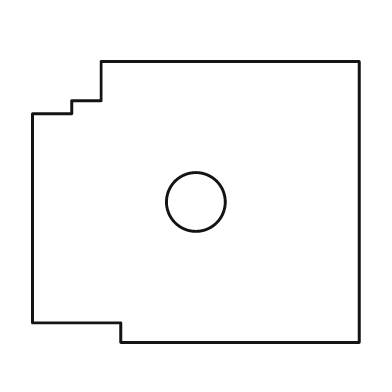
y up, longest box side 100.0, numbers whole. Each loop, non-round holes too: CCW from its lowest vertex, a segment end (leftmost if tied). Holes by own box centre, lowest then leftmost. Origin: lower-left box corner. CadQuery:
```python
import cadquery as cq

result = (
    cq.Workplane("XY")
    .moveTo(27.0, 0.0)
    .lineTo(100.0, 0.0)
    .lineTo(100.0, 86.0)
    .lineTo(21.0, 86.0)
    .lineTo(21.0, 74.0)
    .lineTo(12.0, 74.0)
    .lineTo(12.0, 70.0)
    .lineTo(0.0, 70.0)
    .lineTo(0.0, 6.0)
    .lineTo(27.0, 6.0)
    .close()
    .moveTo(50.0, 43.0)
    .circle(9.0)
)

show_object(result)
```